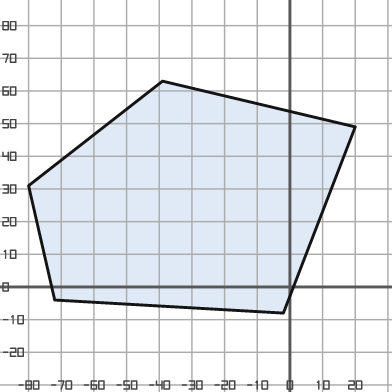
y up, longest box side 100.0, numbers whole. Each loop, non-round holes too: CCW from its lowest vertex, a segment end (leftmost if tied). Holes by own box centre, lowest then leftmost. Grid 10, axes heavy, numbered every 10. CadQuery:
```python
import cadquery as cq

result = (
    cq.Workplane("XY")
    .moveTo(-2.0, -8.0)
    .lineTo(20.0, 49.0)
    .lineTo(-39.0, 63.0)
    .lineTo(-80.0, 31.0)
    .lineTo(-72.0, -4.0)
    .close()
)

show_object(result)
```